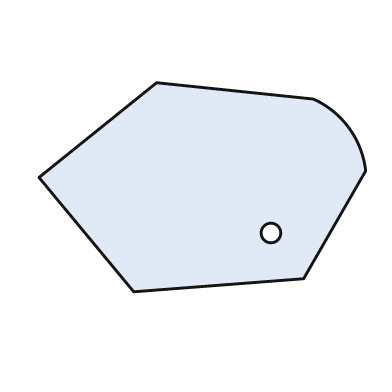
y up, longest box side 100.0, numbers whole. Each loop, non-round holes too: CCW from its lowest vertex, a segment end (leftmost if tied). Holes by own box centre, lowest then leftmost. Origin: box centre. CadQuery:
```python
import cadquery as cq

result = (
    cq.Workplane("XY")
    .moveTo(-21.0, -32.0)
    .lineTo(31.0, -28.0)
    .lineTo(50.0, 5.0)
    .threePointArc((45.0, 18.0), (34.0, 27.0))
    .lineTo(-14.0, 32.0)
    .lineTo(-50.0, 3.0)
    .close()
    .moveTo(21.0, -14.0)
    .circle(3.0)
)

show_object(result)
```